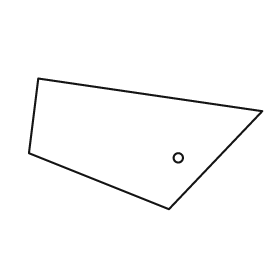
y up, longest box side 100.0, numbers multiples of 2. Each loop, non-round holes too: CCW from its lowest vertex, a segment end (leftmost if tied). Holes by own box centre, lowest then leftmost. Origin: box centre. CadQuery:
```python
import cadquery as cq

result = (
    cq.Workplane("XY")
    .moveTo(10.0, -28.0)
    .lineTo(50.0, 14.0)
    .lineTo(-46.0, 28.0)
    .lineTo(-50.0, -4.0)
    .close()
    .moveTo(14.0, -6.0)
    .circle(2.0)
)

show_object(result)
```